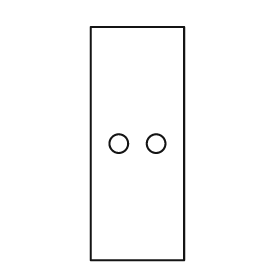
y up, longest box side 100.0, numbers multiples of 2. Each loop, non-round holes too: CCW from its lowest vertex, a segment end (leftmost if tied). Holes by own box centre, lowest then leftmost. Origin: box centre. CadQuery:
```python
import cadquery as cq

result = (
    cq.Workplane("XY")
    .moveTo(-20.0, -50.0)
    .lineTo(20.0, -50.0)
    .lineTo(20.0, 50.0)
    .lineTo(-20.0, 50.0)
    .close()
    .moveTo(-8.0, 0.0)
    .circle(4.0)
    .moveTo(8.0, 0.0)
    .circle(4.0)
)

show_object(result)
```